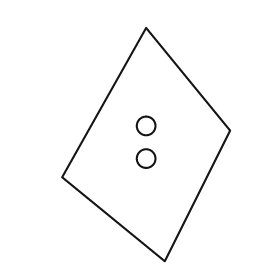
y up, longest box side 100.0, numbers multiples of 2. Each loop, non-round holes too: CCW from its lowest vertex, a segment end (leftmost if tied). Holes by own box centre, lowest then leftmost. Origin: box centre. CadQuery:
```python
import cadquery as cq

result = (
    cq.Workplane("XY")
    .moveTo(8.0, -50.0)
    .lineTo(36.0, 6.0)
    .lineTo(0.0, 50.0)
    .lineTo(-36.0, -14.0)
    .close()
    .moveTo(0.0, -6.0)
    .circle(4.0)
    .moveTo(0.0, 8.0)
    .circle(4.0)
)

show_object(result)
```